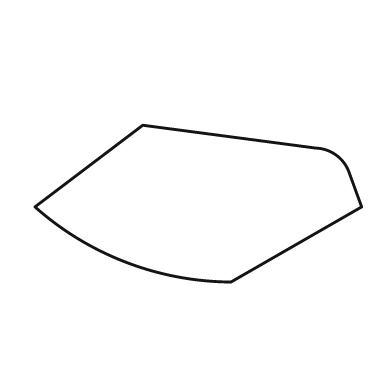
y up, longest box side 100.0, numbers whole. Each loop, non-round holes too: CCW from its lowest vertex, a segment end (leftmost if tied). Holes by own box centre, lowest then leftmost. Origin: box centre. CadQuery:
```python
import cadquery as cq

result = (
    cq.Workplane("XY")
    .moveTo(10.0, -24.0)
    .lineTo(50.0, -1.0)
    .lineTo(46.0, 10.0)
    .threePointArc((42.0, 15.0), (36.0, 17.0))
    .lineTo(-17.0, 24.0)
    .lineTo(-50.0, -1.0)
    .threePointArc((-22.0, -18.0), (10.0, -24.0))
    .close()
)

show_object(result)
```